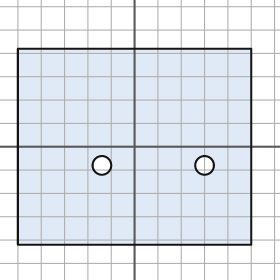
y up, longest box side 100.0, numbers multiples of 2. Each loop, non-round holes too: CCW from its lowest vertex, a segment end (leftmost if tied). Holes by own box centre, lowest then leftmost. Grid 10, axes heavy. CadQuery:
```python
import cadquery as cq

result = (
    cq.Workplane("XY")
    .moveTo(-50.0, -42.0)
    .lineTo(50.0, -42.0)
    .lineTo(50.0, 42.0)
    .lineTo(-50.0, 42.0)
    .close()
    .moveTo(-14.0, -8.0)
    .circle(4.0)
    .moveTo(30.0, -8.0)
    .circle(4.0)
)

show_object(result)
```